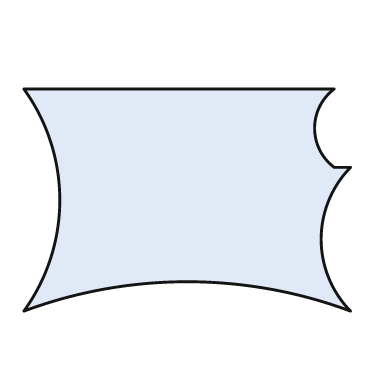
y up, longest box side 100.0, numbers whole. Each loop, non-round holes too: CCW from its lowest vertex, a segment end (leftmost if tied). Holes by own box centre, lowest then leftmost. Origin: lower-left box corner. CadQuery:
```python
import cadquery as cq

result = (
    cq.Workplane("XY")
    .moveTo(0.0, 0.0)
    .threePointArc((50.0, 9.0), (100.0, 0.0))
    .threePointArc((91.0, 22.0), (100.0, 44.0))
    .lineTo(95.0, 44.0)
    .threePointArc((89.0, 56.0), (95.0, 68.0))
    .lineTo(0.0, 68.0)
    .threePointArc((11.0, 34.0), (0.0, 0.0))
    .close()
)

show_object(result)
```